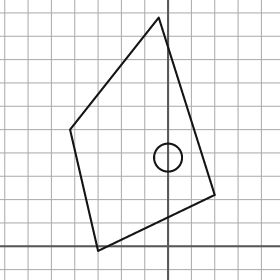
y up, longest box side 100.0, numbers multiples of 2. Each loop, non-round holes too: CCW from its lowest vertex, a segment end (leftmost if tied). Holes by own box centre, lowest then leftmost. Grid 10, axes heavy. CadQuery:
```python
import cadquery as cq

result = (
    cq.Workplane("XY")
    .moveTo(-30.0, -2.0)
    .lineTo(20.0, 22.0)
    .lineTo(-4.0, 98.0)
    .lineTo(-42.0, 50.0)
    .close()
    .moveTo(0.0, 38.0)
    .circle(6.0)
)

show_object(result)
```